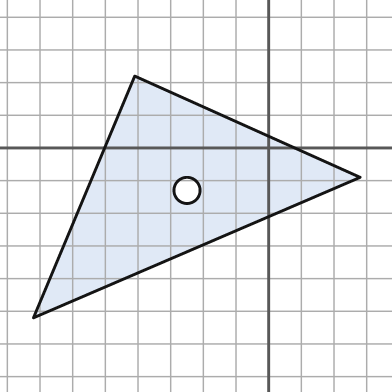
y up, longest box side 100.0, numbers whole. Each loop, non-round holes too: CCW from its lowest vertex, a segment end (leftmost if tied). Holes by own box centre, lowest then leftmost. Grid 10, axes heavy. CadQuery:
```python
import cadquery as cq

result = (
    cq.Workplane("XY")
    .moveTo(-72.0, -52.0)
    .lineTo(28.0, -9.0)
    .lineTo(-41.0, 22.0)
    .close()
    .moveTo(-25.0, -13.0)
    .circle(4.0)
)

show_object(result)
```